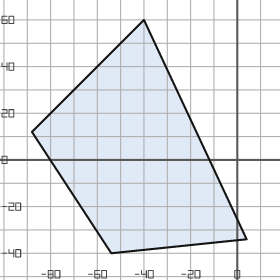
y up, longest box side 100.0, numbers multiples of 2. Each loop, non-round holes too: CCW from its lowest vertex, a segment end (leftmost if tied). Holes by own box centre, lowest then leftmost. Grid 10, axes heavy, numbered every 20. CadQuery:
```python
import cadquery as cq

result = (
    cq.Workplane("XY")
    .moveTo(-54.0, -40.0)
    .lineTo(4.0, -34.0)
    .lineTo(-40.0, 60.0)
    .lineTo(-88.0, 12.0)
    .close()
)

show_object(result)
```